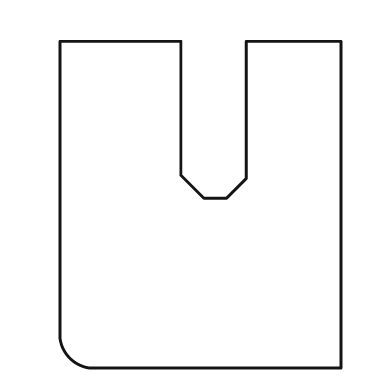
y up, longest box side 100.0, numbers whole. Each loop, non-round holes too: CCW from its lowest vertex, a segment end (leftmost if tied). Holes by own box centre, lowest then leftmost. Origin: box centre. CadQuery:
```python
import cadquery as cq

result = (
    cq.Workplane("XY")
    .moveTo(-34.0, -50.0)
    .lineTo(43.0, -50.0)
    .lineTo(43.0, 50.0)
    .lineTo(14.0, 50.0)
    .lineTo(14.0, 8.0)
    .lineTo(8.0, 2.0)
    .lineTo(1.0, 2.0)
    .lineTo(-6.0, 9.0)
    .lineTo(-6.0, 50.0)
    .lineTo(-43.0, 50.0)
    .lineTo(-43.0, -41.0)
    .threePointArc((-40.0, -47.0), (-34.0, -50.0))
    .close()
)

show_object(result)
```